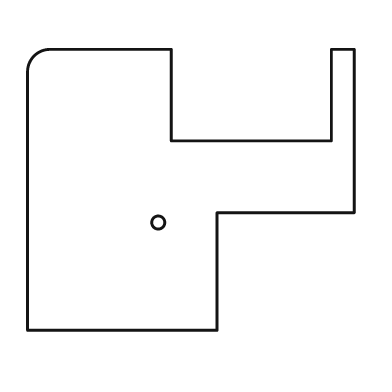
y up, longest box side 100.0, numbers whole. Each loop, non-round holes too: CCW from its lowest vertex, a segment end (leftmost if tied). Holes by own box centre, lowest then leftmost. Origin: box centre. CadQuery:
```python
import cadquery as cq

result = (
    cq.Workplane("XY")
    .moveTo(-50.0, -43.0)
    .lineTo(8.0, -43.0)
    .lineTo(8.0, -7.0)
    .lineTo(50.0, -7.0)
    .lineTo(50.0, 43.0)
    .lineTo(43.0, 43.0)
    .lineTo(43.0, 15.0)
    .lineTo(-6.0, 15.0)
    .lineTo(-6.0, 43.0)
    .lineTo(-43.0, 43.0)
    .threePointArc((-48.0, 41.0), (-50.0, 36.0))
    .close()
    .moveTo(-10.0, -10.0)
    .circle(2.0)
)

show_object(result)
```